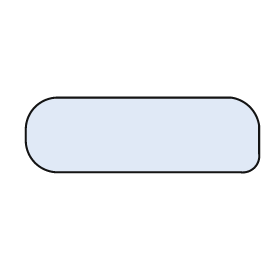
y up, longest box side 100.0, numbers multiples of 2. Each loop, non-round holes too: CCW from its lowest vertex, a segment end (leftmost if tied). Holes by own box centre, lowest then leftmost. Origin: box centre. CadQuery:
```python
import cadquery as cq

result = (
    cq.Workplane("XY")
    .moveTo(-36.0, -16.0)
    .lineTo(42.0, -16.0)
    .threePointArc((48.0, -14.0), (50.0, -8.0))
    .lineTo(50.0, 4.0)
    .threePointArc((46.0, 12.0), (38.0, 16.0))
    .lineTo(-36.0, 16.0)
    .threePointArc((-46.0, 12.0), (-50.0, 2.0))
    .lineTo(-50.0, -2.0)
    .threePointArc((-46.0, -12.0), (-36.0, -16.0))
    .close()
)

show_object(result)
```